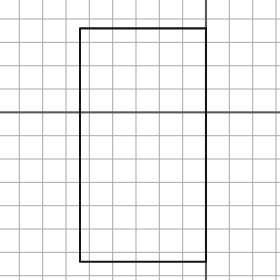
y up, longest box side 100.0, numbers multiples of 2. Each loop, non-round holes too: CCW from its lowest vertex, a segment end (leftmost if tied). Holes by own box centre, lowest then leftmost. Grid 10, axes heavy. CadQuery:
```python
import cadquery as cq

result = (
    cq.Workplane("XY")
    .moveTo(-54.0, -64.0)
    .lineTo(0.0, -64.0)
    .lineTo(0.0, 36.0)
    .lineTo(-54.0, 36.0)
    .close()
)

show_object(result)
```